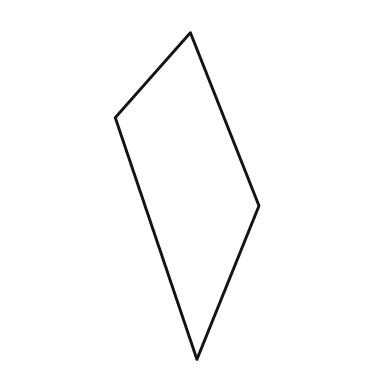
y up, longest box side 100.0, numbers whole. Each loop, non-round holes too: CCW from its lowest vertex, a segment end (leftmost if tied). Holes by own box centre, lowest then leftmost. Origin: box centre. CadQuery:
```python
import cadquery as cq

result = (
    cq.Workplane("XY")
    .moveTo(3.0, -50.0)
    .lineTo(22.0, -3.0)
    .lineTo(1.0, 50.0)
    .lineTo(-22.0, 24.0)
    .close()
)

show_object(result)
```